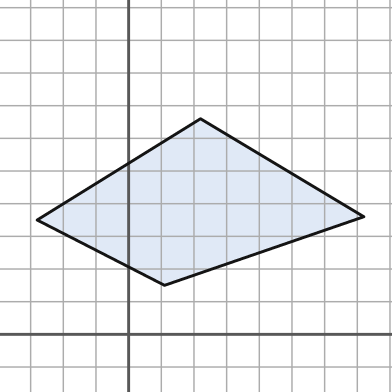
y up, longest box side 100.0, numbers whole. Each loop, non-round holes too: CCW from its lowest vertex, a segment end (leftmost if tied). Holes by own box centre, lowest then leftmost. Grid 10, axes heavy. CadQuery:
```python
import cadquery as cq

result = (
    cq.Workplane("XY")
    .moveTo(11.0, 15.0)
    .lineTo(72.0, 36.0)
    .lineTo(22.0, 66.0)
    .lineTo(-28.0, 35.0)
    .close()
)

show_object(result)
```